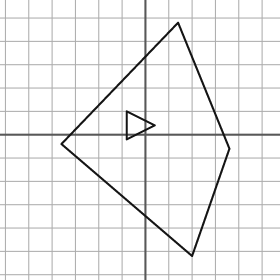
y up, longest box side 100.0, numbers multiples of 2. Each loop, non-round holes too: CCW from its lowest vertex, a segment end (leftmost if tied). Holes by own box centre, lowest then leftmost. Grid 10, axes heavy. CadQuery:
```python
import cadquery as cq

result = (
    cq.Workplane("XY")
    .moveTo(20.0, -52.0)
    .lineTo(36.0, -6.0)
    .lineTo(14.0, 48.0)
    .lineTo(-36.0, -4.0)
    .close()
    .moveTo(-8.0, -2.0)
    .lineTo(4.0, 4.0)
    .lineTo(-8.0, 10.0)
    .close()
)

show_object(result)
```